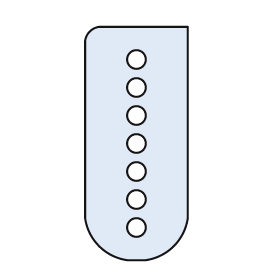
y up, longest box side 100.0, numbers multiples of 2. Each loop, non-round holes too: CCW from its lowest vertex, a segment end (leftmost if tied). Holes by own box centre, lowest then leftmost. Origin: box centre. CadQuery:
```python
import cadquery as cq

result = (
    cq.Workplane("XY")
    .moveTo(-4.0, -50.0)
    .lineTo(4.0, -50.0)
    .threePointArc((16.0, -44.0), (22.0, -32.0))
    .lineTo(22.0, 50.0)
    .lineTo(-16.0, 50.0)
    .threePointArc((-20.0, 48.0), (-22.0, 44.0))
    .lineTo(-22.0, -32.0)
    .threePointArc((-16.0, -44.0), (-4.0, -50.0))
    .close()
    .moveTo(0.0, -36.0)
    .circle(4.0)
    .moveTo(0.0, -24.0)
    .circle(4.0)
    .moveTo(0.0, -12.0)
    .circle(4.0)
    .moveTo(0.0, 0.0)
    .circle(4.0)
    .moveTo(0.0, 12.0)
    .circle(4.0)
    .moveTo(0.0, 24.0)
    .circle(4.0)
    .moveTo(0.0, 36.0)
    .circle(4.0)
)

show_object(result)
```